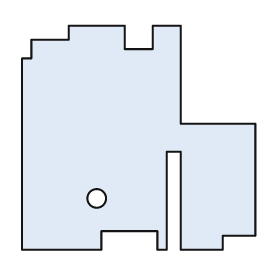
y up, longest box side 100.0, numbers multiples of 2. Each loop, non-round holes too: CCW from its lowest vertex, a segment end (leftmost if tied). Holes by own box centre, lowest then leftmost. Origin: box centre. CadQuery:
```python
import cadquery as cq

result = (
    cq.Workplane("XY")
    .moveTo(-50.0, -48.0)
    .lineTo(-16.0, -48.0)
    .lineTo(-16.0, -40.0)
    .lineTo(8.0, -40.0)
    .lineTo(8.0, -48.0)
    .lineTo(12.0, -48.0)
    .lineTo(12.0, -6.0)
    .lineTo(18.0, -6.0)
    .lineTo(18.0, -48.0)
    .lineTo(36.0, -48.0)
    .lineTo(36.0, -42.0)
    .lineTo(50.0, -42.0)
    .lineTo(50.0, 6.0)
    .lineTo(18.0, 6.0)
    .lineTo(18.0, 48.0)
    .lineTo(6.0, 48.0)
    .lineTo(6.0, 38.0)
    .lineTo(-6.0, 38.0)
    .lineTo(-6.0, 48.0)
    .lineTo(-30.0, 48.0)
    .lineTo(-30.0, 42.0)
    .lineTo(-46.0, 42.0)
    .lineTo(-46.0, 34.0)
    .lineTo(-50.0, 34.0)
    .close()
    .moveTo(-18.0, -26.0)
    .circle(4.0)
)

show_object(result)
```